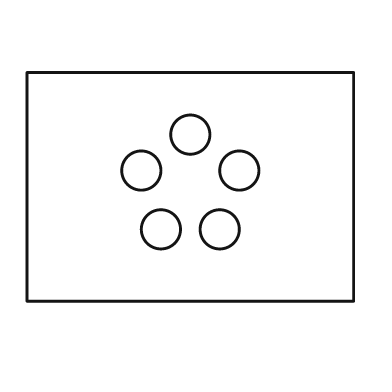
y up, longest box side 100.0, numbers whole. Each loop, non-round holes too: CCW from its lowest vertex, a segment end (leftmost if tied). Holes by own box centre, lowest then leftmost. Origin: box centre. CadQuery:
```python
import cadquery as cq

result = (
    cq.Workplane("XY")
    .moveTo(-50.0, -35.0)
    .lineTo(50.0, -35.0)
    .lineTo(50.0, 35.0)
    .lineTo(-50.0, 35.0)
    .close()
    .moveTo(-9.0, -13.0)
    .circle(6.0)
    .moveTo(9.0, -13.0)
    .circle(6.0)
    .moveTo(-15.0, 5.0)
    .circle(6.0)
    .moveTo(15.0, 5.0)
    .circle(6.0)
    .moveTo(0.0, 16.0)
    .circle(6.0)
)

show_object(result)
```